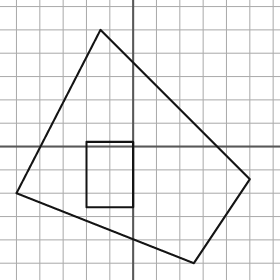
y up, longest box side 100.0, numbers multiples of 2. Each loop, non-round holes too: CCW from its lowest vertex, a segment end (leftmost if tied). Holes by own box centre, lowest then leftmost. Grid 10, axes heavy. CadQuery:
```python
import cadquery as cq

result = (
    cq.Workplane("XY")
    .moveTo(26.0, -50.0)
    .lineTo(50.0, -14.0)
    .lineTo(-14.0, 50.0)
    .lineTo(-50.0, -20.0)
    .close()
    .moveTo(-20.0, -26.0)
    .lineTo(0.0, -26.0)
    .lineTo(0.0, 2.0)
    .lineTo(-20.0, 2.0)
    .close()
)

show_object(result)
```